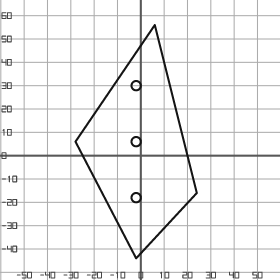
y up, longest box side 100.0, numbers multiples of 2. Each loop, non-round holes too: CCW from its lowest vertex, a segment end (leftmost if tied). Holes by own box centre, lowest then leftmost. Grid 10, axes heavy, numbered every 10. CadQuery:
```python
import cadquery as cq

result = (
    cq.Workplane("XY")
    .moveTo(-2.0, -44.0)
    .lineTo(24.0, -16.0)
    .lineTo(6.0, 56.0)
    .lineTo(-28.0, 6.0)
    .close()
    .moveTo(-2.0, -18.0)
    .circle(2.0)
    .moveTo(-2.0, 6.0)
    .circle(2.0)
    .moveTo(-2.0, 30.0)
    .circle(2.0)
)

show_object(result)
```